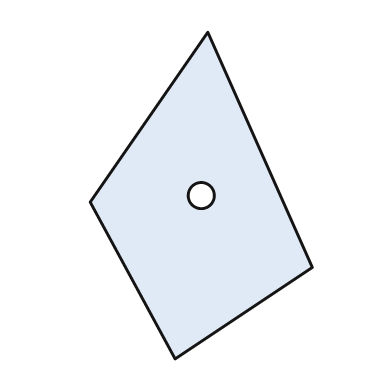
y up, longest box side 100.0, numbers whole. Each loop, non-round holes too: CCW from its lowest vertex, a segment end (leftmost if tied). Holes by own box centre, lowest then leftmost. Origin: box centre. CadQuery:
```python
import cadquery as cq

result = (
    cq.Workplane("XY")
    .moveTo(-8.0, -50.0)
    .lineTo(34.0, -22.0)
    .lineTo(2.0, 50.0)
    .lineTo(-34.0, -2.0)
    .close()
    .moveTo(0.0, 0.0)
    .circle(4.0)
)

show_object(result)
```